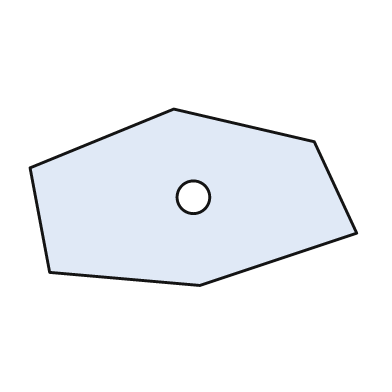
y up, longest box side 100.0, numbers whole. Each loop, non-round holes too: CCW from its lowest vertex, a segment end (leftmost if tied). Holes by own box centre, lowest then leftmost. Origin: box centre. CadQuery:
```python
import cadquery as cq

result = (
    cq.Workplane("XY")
    .moveTo(2.0, -27.0)
    .lineTo(50.0, -11.0)
    .lineTo(37.0, 17.0)
    .lineTo(-6.0, 27.0)
    .lineTo(-50.0, 9.0)
    .lineTo(-44.0, -23.0)
    .close()
    .moveTo(0.0, 0.0)
    .circle(5.0)
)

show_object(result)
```